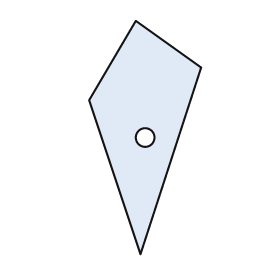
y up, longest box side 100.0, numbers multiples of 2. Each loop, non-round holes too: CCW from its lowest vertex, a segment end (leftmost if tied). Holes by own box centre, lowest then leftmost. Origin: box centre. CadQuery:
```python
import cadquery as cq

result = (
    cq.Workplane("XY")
    .moveTo(-2.0, -50.0)
    .lineTo(24.0, 30.0)
    .lineTo(-4.0, 50.0)
    .lineTo(-24.0, 16.0)
    .close()
    .moveTo(0.0, 0.0)
    .circle(4.0)
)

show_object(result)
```